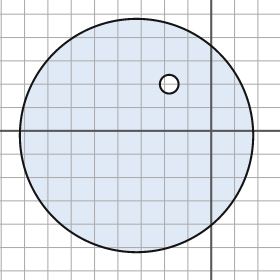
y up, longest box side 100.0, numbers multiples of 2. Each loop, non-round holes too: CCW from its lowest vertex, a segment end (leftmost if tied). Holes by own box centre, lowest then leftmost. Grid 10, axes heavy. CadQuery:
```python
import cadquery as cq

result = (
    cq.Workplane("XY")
    .moveTo(-32.0, -2.0)
    .circle(50.0)
    .moveTo(-18.0, 20.0)
    .circle(4.0)
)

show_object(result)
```